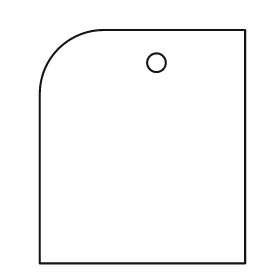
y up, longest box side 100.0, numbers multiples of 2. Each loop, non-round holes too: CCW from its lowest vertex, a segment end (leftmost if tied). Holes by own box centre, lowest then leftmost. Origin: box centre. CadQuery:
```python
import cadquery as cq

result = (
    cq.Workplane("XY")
    .moveTo(-44.0, -50.0)
    .lineTo(44.0, -50.0)
    .lineTo(44.0, 50.0)
    .lineTo(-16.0, 50.0)
    .threePointArc((-36.0, 42.0), (-44.0, 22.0))
    .close()
    .moveTo(6.0, 36.0)
    .circle(4.0)
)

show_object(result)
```